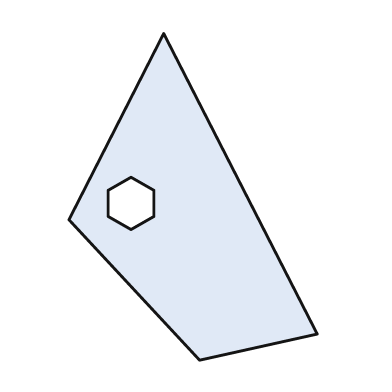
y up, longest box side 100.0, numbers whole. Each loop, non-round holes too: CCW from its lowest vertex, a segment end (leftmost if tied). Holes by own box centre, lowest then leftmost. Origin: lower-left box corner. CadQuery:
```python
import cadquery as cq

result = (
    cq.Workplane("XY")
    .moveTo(40.0, 0.0)
    .lineTo(76.0, 8.0)
    .lineTo(29.0, 100.0)
    .lineTo(0.0, 43.0)
    .close()
    .moveTo(19.0, 40.0)
    .lineTo(26.0, 44.0)
    .lineTo(26.0, 52.0)
    .lineTo(19.0, 56.0)
    .lineTo(12.0, 52.0)
    .lineTo(12.0, 44.0)
    .close()
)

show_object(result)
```